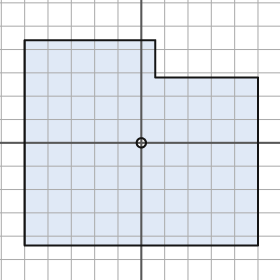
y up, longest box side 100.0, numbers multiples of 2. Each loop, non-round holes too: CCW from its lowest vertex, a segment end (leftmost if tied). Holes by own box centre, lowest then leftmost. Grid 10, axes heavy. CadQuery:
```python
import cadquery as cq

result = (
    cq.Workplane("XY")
    .moveTo(-50.0, -44.0)
    .lineTo(50.0, -44.0)
    .lineTo(50.0, 28.0)
    .lineTo(6.0, 28.0)
    .lineTo(6.0, 44.0)
    .lineTo(-50.0, 44.0)
    .close()
    .moveTo(0.0, 0.0)
    .circle(2.0)
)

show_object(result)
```